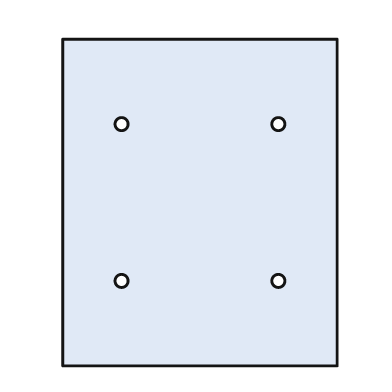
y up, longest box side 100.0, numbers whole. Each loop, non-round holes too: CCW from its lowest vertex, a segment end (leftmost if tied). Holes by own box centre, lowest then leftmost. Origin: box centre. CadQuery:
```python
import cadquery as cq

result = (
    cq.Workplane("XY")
    .moveTo(-42.0, -50.0)
    .lineTo(42.0, -50.0)
    .lineTo(42.0, 50.0)
    .lineTo(-42.0, 50.0)
    .close()
    .moveTo(-24.0, -24.0)
    .circle(2.0)
    .moveTo(24.0, -24.0)
    .circle(2.0)
    .moveTo(-24.0, 24.0)
    .circle(2.0)
    .moveTo(24.0, 24.0)
    .circle(2.0)
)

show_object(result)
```